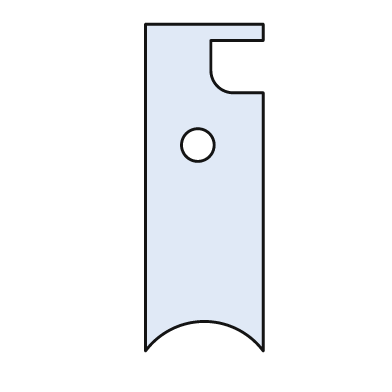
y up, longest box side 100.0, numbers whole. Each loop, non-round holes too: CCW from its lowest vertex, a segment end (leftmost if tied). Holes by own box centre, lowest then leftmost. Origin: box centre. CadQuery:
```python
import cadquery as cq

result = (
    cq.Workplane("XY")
    .moveTo(-18.0, -50.0)
    .threePointArc((0.0, -41.0), (18.0, -50.0))
    .lineTo(18.0, 29.0)
    .lineTo(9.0, 29.0)
    .threePointArc((4.0, 31.0), (2.0, 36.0))
    .lineTo(2.0, 45.0)
    .lineTo(18.0, 45.0)
    .lineTo(18.0, 50.0)
    .lineTo(-18.0, 50.0)
    .close()
    .moveTo(-2.0, 13.0)
    .circle(5.0)
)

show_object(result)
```